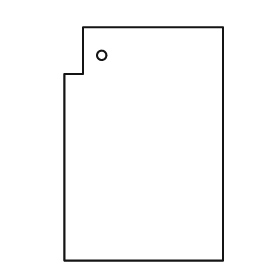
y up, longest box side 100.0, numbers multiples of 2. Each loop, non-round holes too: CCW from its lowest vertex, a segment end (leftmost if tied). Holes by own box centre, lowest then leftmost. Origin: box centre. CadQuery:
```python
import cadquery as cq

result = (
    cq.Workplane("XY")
    .moveTo(-34.0, -50.0)
    .lineTo(34.0, -50.0)
    .lineTo(34.0, 50.0)
    .lineTo(-26.0, 50.0)
    .lineTo(-26.0, 30.0)
    .lineTo(-34.0, 30.0)
    .close()
    .moveTo(-18.0, 38.0)
    .circle(2.0)
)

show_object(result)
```